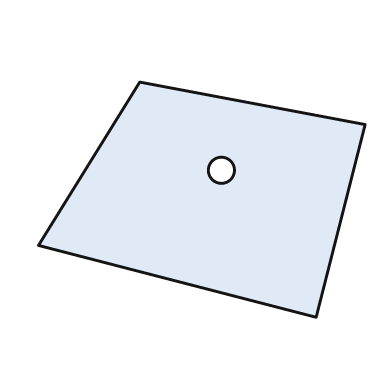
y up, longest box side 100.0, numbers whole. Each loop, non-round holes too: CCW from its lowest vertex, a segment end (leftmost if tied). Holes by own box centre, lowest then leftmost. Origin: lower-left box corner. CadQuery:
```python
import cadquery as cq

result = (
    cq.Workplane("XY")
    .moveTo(85.0, 0.0)
    .lineTo(100.0, 59.0)
    .lineTo(31.0, 72.0)
    .lineTo(0.0, 22.0)
    .close()
    .moveTo(56.0, 45.0)
    .circle(4.0)
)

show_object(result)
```